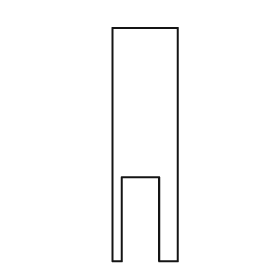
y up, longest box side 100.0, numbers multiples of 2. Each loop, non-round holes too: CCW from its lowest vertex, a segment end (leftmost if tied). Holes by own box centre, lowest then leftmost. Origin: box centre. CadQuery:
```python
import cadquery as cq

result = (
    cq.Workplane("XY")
    .moveTo(-14.0, -50.0)
    .lineTo(-10.0, -50.0)
    .lineTo(-10.0, -14.0)
    .lineTo(6.0, -14.0)
    .lineTo(6.0, -50.0)
    .lineTo(14.0, -50.0)
    .lineTo(14.0, 50.0)
    .lineTo(-14.0, 50.0)
    .close()
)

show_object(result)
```